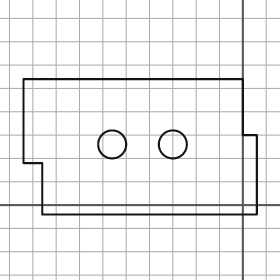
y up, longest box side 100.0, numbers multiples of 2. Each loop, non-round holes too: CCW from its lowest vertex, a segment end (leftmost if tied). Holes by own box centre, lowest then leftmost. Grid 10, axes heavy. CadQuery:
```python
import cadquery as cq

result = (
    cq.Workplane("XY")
    .moveTo(-86.0, -4.0)
    .lineTo(6.0, -4.0)
    .lineTo(6.0, 30.0)
    .lineTo(0.0, 30.0)
    .lineTo(0.0, 54.0)
    .lineTo(-94.0, 54.0)
    .lineTo(-94.0, 18.0)
    .lineTo(-86.0, 18.0)
    .close()
    .moveTo(-56.0, 26.0)
    .circle(6.0)
    .moveTo(-30.0, 26.0)
    .circle(6.0)
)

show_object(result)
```